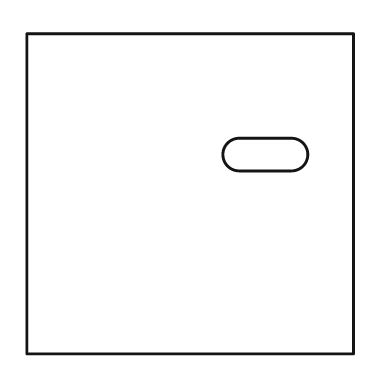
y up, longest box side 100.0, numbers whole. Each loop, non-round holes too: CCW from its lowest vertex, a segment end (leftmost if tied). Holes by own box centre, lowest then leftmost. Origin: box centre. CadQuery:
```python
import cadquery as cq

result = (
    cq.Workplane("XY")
    .moveTo(-50.0, -49.0)
    .lineTo(50.0, -49.0)
    .lineTo(50.0, 49.0)
    .lineTo(-50.0, 49.0)
    .close()
    .moveTo(15.0, 7.0)
    .lineTo(31.0, 7.0)
    .threePointArc((36.0, 12.0), (31.0, 17.0))
    .lineTo(15.0, 17.0)
    .threePointArc((10.0, 12.0), (15.0, 7.0))
    .close()
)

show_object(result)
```